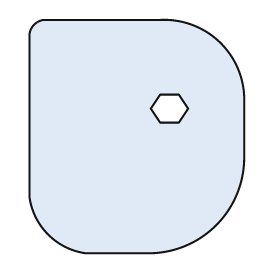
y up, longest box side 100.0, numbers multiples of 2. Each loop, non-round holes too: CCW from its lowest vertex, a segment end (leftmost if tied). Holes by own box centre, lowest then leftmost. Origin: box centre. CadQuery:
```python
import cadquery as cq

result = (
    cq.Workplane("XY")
    .moveTo(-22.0, -50.0)
    .lineTo(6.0, -50.0)
    .threePointArc((34.0, -38.0), (46.0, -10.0))
    .lineTo(46.0, 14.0)
    .threePointArc((36.0, 40.0), (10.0, 50.0))
    .lineTo(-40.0, 50.0)
    .threePointArc((-44.0, 48.0), (-46.0, 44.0))
    .lineTo(-46.0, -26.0)
    .threePointArc((-38.0, -42.0), (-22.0, -50.0))
    .close()
    .moveTo(10.0, 6.0)
    .lineTo(18.0, 6.0)
    .lineTo(22.0, 12.0)
    .lineTo(18.0, 18.0)
    .lineTo(10.0, 18.0)
    .lineTo(6.0, 12.0)
    .close()
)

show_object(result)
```